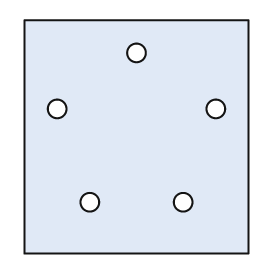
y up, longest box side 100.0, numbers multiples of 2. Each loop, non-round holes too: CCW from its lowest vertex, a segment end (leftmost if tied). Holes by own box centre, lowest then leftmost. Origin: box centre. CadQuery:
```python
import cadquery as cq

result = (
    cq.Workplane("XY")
    .moveTo(-48.0, -50.0)
    .lineTo(48.0, -50.0)
    .lineTo(48.0, 50.0)
    .lineTo(-48.0, 50.0)
    .close()
    .moveTo(-20.0, -28.0)
    .circle(4.0)
    .moveTo(20.0, -28.0)
    .circle(4.0)
    .moveTo(-34.0, 12.0)
    .circle(4.0)
    .moveTo(34.0, 12.0)
    .circle(4.0)
    .moveTo(0.0, 36.0)
    .circle(4.0)
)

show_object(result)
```